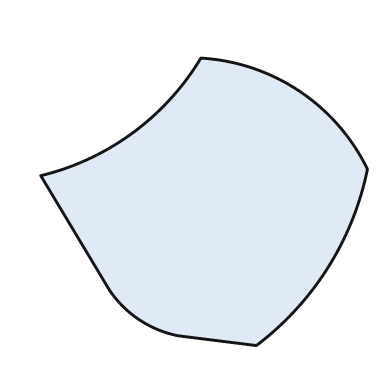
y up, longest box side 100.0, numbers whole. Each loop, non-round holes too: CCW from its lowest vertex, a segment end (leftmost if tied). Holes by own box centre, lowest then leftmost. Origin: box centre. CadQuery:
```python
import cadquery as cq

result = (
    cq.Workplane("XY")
    .moveTo(16.0, -44.0)
    .threePointArc((38.0, -20.0), (50.0, 10.0))
    .threePointArc((29.0, 34.0), (-1.0, 44.0))
    .threePointArc((-22.0, 21.0), (-50.0, 8.0))
    .lineTo(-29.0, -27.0)
    .threePointArc((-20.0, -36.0), (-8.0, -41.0))
    .close()
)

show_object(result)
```